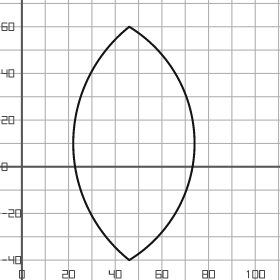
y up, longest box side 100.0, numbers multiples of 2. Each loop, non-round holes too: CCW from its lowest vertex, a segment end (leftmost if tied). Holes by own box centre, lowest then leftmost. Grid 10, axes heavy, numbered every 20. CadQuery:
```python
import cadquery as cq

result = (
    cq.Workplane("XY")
    .moveTo(46.0, -40.0)
    .threePointArc((74.0, 10.0), (46.0, 60.0))
    .threePointArc((22.0, 10.0), (46.0, -40.0))
    .close()
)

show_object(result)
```